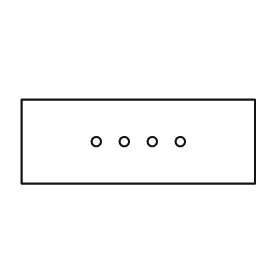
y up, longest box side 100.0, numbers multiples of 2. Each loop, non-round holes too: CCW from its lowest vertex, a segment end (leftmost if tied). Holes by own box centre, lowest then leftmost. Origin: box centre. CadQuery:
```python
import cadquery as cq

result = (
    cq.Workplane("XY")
    .moveTo(-50.0, -18.0)
    .lineTo(50.0, -18.0)
    .lineTo(50.0, 18.0)
    .lineTo(-50.0, 18.0)
    .close()
    .moveTo(-18.0, 0.0)
    .circle(2.0)
    .moveTo(-6.0, 0.0)
    .circle(2.0)
    .moveTo(6.0, 0.0)
    .circle(2.0)
    .moveTo(18.0, 0.0)
    .circle(2.0)
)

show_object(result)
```